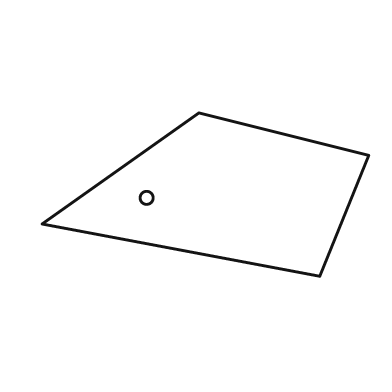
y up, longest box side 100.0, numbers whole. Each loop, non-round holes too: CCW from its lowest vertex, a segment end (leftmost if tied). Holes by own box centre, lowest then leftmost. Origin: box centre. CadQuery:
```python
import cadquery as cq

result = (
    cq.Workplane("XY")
    .moveTo(35.0, -25.0)
    .lineTo(50.0, 12.0)
    .lineTo(-2.0, 25.0)
    .lineTo(-50.0, -9.0)
    .close()
    .moveTo(-18.0, -1.0)
    .circle(2.0)
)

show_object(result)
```